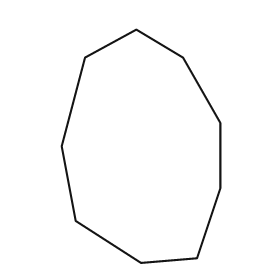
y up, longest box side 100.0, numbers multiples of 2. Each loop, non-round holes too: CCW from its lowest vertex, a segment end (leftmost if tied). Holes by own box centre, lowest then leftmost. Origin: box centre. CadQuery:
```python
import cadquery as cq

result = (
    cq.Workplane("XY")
    .moveTo(0.0, -50.0)
    .lineTo(24.0, -48.0)
    .lineTo(34.0, -18.0)
    .lineTo(34.0, 10.0)
    .lineTo(18.0, 38.0)
    .lineTo(-2.0, 50.0)
    .lineTo(-24.0, 38.0)
    .lineTo(-34.0, 0.0)
    .lineTo(-28.0, -32.0)
    .close()
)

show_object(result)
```